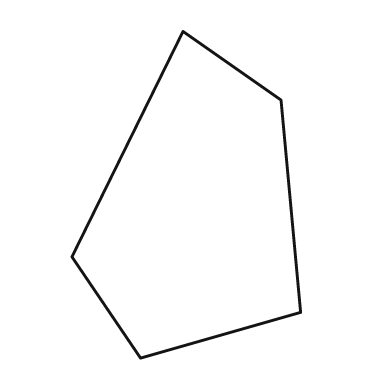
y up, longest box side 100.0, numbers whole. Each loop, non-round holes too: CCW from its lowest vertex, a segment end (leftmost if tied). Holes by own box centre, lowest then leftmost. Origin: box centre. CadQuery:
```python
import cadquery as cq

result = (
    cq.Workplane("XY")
    .moveTo(-14.0, -50.0)
    .lineTo(35.0, -36.0)
    .lineTo(29.0, 29.0)
    .lineTo(-1.0, 50.0)
    .lineTo(-35.0, -19.0)
    .close()
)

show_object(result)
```